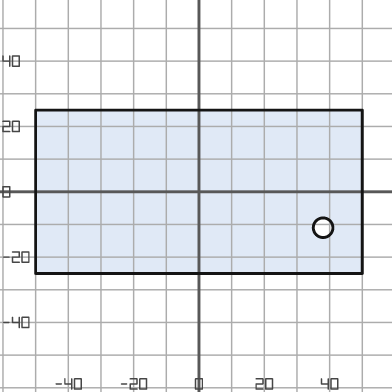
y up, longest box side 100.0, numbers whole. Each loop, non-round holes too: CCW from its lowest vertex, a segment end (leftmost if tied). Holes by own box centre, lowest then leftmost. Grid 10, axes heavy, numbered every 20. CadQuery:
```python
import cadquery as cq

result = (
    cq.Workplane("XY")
    .moveTo(-50.0, -25.0)
    .lineTo(50.0, -25.0)
    .lineTo(50.0, 25.0)
    .lineTo(-50.0, 25.0)
    .close()
    .moveTo(38.0, -11.0)
    .circle(3.0)
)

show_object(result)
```